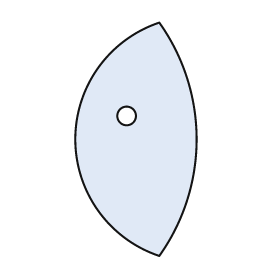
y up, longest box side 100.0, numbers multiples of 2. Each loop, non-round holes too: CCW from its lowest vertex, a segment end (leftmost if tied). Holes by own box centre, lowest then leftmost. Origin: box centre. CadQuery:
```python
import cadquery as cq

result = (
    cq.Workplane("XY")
    .moveTo(10.0, -50.0)
    .threePointArc((26.0, 0.0), (10.0, 50.0))
    .threePointArc((-26.0, 0.0), (10.0, -50.0))
    .close()
    .moveTo(-4.0, 10.0)
    .circle(4.0)
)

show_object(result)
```